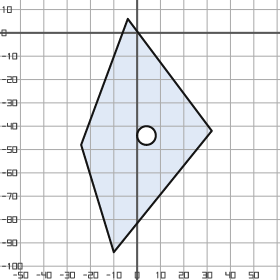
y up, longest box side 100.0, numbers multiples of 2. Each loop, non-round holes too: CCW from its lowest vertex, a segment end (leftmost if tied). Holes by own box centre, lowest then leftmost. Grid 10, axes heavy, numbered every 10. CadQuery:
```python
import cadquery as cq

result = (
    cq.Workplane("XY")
    .moveTo(-10.0, -94.0)
    .lineTo(32.0, -42.0)
    .lineTo(-4.0, 6.0)
    .lineTo(-24.0, -48.0)
    .close()
    .moveTo(4.0, -44.0)
    .circle(4.0)
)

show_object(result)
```